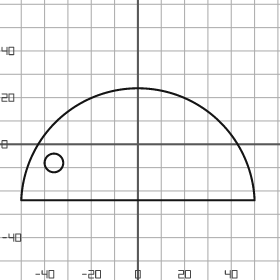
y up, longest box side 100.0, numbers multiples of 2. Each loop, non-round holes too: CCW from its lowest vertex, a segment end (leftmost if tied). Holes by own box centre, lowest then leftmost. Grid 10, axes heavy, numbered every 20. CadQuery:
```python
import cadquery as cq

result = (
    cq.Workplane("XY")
    .moveTo(-50.0, -24.0)
    .lineTo(50.0, -24.0)
    .threePointArc((0.0, 24.0), (-50.0, -24.0))
    .close()
    .moveTo(-36.0, -8.0)
    .circle(4.0)
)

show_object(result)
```